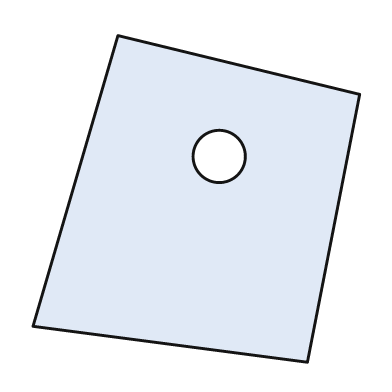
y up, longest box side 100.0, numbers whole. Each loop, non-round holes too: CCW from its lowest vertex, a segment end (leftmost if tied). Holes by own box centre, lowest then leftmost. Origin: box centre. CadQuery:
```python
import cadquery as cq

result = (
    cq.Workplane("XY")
    .moveTo(34.0, -50.0)
    .lineTo(50.0, 32.0)
    .lineTo(-24.0, 50.0)
    .lineTo(-50.0, -39.0)
    .close()
    .moveTo(7.0, 13.0)
    .circle(8.0)
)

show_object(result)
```